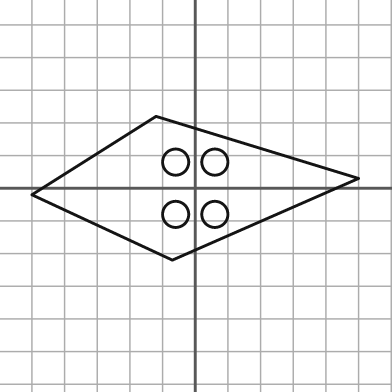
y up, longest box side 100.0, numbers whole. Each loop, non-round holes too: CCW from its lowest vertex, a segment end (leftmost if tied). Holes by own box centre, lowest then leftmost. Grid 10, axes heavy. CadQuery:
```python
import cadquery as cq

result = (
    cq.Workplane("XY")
    .moveTo(-7.0, -22.0)
    .lineTo(50.0, 3.0)
    .lineTo(-12.0, 22.0)
    .lineTo(-50.0, -2.0)
    .close()
    .moveTo(-6.0, -8.0)
    .circle(4.0)
    .moveTo(6.0, -8.0)
    .circle(4.0)
    .moveTo(-6.0, 8.0)
    .circle(4.0)
    .moveTo(6.0, 8.0)
    .circle(4.0)
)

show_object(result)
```